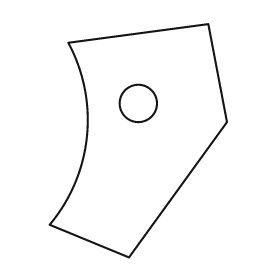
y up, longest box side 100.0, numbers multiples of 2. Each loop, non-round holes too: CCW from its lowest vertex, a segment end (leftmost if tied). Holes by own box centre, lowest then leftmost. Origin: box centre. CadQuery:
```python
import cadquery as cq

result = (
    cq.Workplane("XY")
    .moveTo(-4.0, -50.0)
    .lineTo(38.0, 8.0)
    .lineTo(30.0, 50.0)
    .lineTo(-30.0, 42.0)
    .threePointArc((-22.0, 2.0), (-38.0, -36.0))
    .close()
    .moveTo(0.0, 16.0)
    .circle(8.0)
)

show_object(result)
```